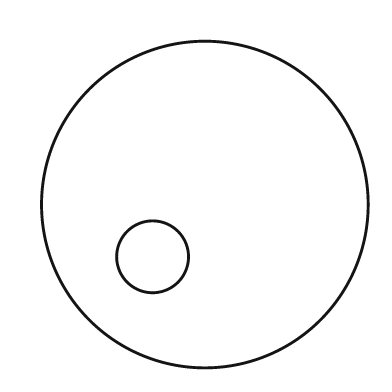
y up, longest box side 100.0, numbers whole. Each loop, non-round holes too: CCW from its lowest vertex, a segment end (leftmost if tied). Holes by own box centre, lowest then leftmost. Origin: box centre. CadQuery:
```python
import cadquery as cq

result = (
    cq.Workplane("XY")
    .moveTo(0.0, 0.0)
    .circle(50.0)
    .moveTo(-16.0, -16.0)
    .circle(11.0)
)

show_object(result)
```